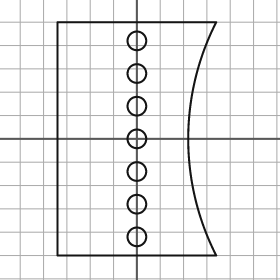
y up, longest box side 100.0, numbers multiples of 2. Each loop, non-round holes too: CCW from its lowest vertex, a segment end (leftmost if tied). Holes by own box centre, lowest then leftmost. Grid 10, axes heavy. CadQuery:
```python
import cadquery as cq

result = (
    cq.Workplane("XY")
    .moveTo(-34.0, -50.0)
    .lineTo(34.0, -50.0)
    .threePointArc((22.0, 0.0), (34.0, 50.0))
    .lineTo(-34.0, 50.0)
    .close()
    .moveTo(0.0, -42.0)
    .circle(4.0)
    .moveTo(0.0, -28.0)
    .circle(4.0)
    .moveTo(0.0, -14.0)
    .circle(4.0)
    .moveTo(0.0, 0.0)
    .circle(4.0)
    .moveTo(0.0, 14.0)
    .circle(4.0)
    .moveTo(0.0, 28.0)
    .circle(4.0)
    .moveTo(0.0, 42.0)
    .circle(4.0)
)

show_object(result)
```